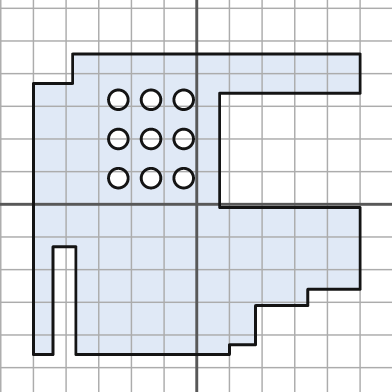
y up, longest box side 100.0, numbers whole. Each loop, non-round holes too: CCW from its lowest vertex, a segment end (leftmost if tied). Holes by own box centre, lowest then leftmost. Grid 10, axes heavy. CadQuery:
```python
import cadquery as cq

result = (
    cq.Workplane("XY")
    .moveTo(-50.0, -46.0)
    .lineTo(-44.0, -46.0)
    .lineTo(-44.0, -13.0)
    .lineTo(-37.0, -13.0)
    .lineTo(-37.0, -46.0)
    .lineTo(10.0, -46.0)
    .lineTo(10.0, -43.0)
    .lineTo(18.0, -43.0)
    .lineTo(18.0, -31.0)
    .lineTo(34.0, -31.0)
    .lineTo(34.0, -26.0)
    .lineTo(50.0, -26.0)
    .lineTo(50.0, -1.0)
    .lineTo(7.0, -1.0)
    .lineTo(7.0, 34.0)
    .lineTo(50.0, 34.0)
    .lineTo(50.0, 46.0)
    .lineTo(-38.0, 46.0)
    .lineTo(-38.0, 37.0)
    .lineTo(-50.0, 37.0)
    .close()
    .moveTo(-24.0, 8.0)
    .circle(3.0)
    .moveTo(-14.0, 8.0)
    .circle(3.0)
    .moveTo(-4.0, 8.0)
    .circle(3.0)
    .moveTo(-24.0, 20.0)
    .circle(3.0)
    .moveTo(-14.0, 20.0)
    .circle(3.0)
    .moveTo(-4.0, 20.0)
    .circle(3.0)
    .moveTo(-24.0, 32.0)
    .circle(3.0)
    .moveTo(-14.0, 32.0)
    .circle(3.0)
    .moveTo(-4.0, 32.0)
    .circle(3.0)
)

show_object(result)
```